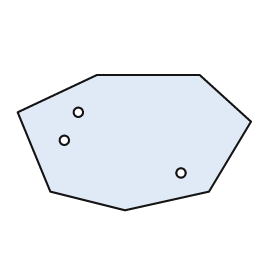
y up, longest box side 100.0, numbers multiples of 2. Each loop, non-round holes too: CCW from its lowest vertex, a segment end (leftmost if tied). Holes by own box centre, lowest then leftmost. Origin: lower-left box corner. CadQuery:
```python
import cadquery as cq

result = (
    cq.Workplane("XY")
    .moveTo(46.0, 0.0)
    .lineTo(82.0, 8.0)
    .lineTo(100.0, 38.0)
    .lineTo(78.0, 58.0)
    .lineTo(34.0, 58.0)
    .lineTo(0.0, 42.0)
    .lineTo(14.0, 8.0)
    .close()
    .moveTo(70.0, 16.0)
    .circle(2.0)
    .moveTo(20.0, 30.0)
    .circle(2.0)
    .moveTo(26.0, 42.0)
    .circle(2.0)
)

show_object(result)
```